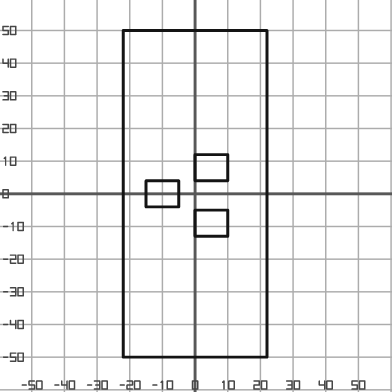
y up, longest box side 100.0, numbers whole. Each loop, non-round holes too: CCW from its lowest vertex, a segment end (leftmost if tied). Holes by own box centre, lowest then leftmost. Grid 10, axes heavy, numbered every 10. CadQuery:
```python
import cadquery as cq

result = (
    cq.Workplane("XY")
    .moveTo(-22.0, -50.0)
    .lineTo(22.0, -50.0)
    .lineTo(22.0, 50.0)
    .lineTo(-22.0, 50.0)
    .close()
    .moveTo(0.0, -13.0)
    .lineTo(10.0, -13.0)
    .lineTo(10.0, -5.0)
    .lineTo(0.0, -5.0)
    .close()
    .moveTo(-15.0, -4.0)
    .lineTo(-5.0, -4.0)
    .lineTo(-5.0, 4.0)
    .lineTo(-15.0, 4.0)
    .close()
    .moveTo(0.0, 4.0)
    .lineTo(10.0, 4.0)
    .lineTo(10.0, 12.0)
    .lineTo(0.0, 12.0)
    .close()
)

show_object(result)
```